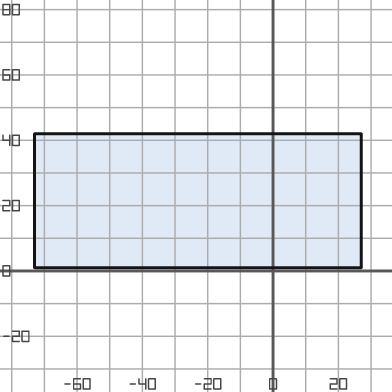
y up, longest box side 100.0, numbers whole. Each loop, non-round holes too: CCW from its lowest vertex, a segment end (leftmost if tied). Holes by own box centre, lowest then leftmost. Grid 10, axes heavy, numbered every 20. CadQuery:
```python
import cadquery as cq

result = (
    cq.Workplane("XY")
    .moveTo(-73.0, 1.0)
    .lineTo(27.0, 1.0)
    .lineTo(27.0, 42.0)
    .lineTo(-73.0, 42.0)
    .close()
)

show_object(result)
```